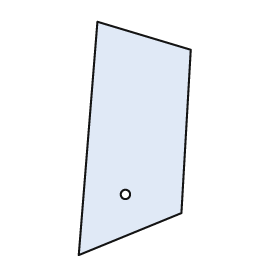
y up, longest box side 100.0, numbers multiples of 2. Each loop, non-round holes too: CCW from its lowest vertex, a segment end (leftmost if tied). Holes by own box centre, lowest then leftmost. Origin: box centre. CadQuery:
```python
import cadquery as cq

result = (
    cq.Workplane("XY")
    .moveTo(-24.0, -50.0)
    .lineTo(20.0, -32.0)
    .lineTo(24.0, 38.0)
    .lineTo(-16.0, 50.0)
    .close()
    .moveTo(-4.0, -24.0)
    .circle(2.0)
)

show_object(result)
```